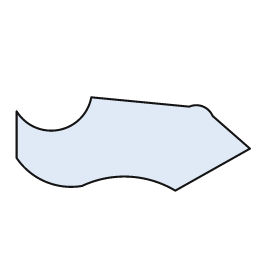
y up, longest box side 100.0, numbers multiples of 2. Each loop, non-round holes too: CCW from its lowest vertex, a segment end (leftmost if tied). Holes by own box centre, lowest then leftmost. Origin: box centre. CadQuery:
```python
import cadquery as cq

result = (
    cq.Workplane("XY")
    .moveTo(18.0, -20.0)
    .lineTo(50.0, -2.0)
    .lineTo(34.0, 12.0)
    .threePointArc((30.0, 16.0), (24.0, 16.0))
    .lineTo(-18.0, 20.0)
    .threePointArc((-32.0, 6.0), (-50.0, 14.0))
    .lineTo(-50.0, -6.0)
    .threePointArc((-38.0, -16.0), (-22.0, -18.0))
    .threePointArc((-2.0, -14.0), (18.0, -20.0))
    .close()
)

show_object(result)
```